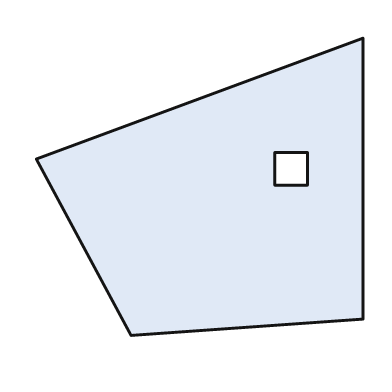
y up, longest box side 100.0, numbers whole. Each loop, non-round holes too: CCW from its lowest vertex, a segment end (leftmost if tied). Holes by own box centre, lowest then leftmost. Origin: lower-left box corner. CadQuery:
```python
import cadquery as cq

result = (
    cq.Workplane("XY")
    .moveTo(29.0, 0.0)
    .lineTo(100.0, 5.0)
    .lineTo(100.0, 91.0)
    .lineTo(0.0, 54.0)
    .close()
    .moveTo(73.0, 46.0)
    .lineTo(83.0, 46.0)
    .lineTo(83.0, 56.0)
    .lineTo(73.0, 56.0)
    .close()
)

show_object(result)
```